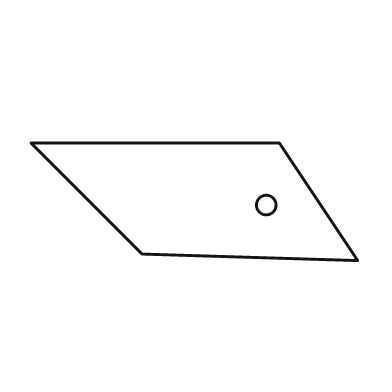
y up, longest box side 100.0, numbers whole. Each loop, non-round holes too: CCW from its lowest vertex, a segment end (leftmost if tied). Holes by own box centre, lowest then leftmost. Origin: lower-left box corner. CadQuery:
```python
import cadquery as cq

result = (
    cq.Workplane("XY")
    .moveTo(100.0, 0.0)
    .lineTo(76.0, 36.0)
    .lineTo(0.0, 36.0)
    .lineTo(34.0, 2.0)
    .close()
    .moveTo(72.0, 17.0)
    .circle(3.0)
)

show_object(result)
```